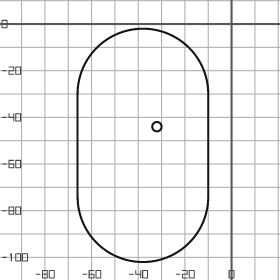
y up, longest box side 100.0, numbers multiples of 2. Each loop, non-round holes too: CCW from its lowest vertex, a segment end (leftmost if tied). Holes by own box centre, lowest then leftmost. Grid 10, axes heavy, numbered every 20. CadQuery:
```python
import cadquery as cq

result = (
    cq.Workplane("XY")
    .moveTo(-66.0, -74.0)
    .threePointArc((-38.0, -102.0), (-10.0, -74.0))
    .lineTo(-10.0, -30.0)
    .threePointArc((-38.0, -2.0), (-66.0, -30.0))
    .close()
    .moveTo(-32.0, -44.0)
    .circle(2.0)
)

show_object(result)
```